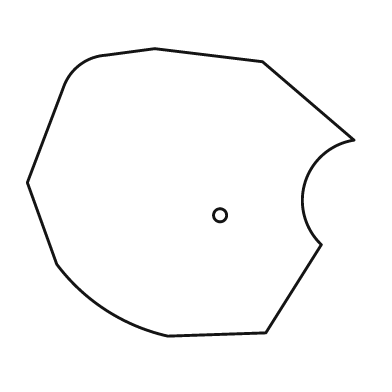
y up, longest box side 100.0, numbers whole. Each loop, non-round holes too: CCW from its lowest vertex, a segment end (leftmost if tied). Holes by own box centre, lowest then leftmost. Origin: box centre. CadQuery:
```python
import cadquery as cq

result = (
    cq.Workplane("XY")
    .moveTo(-7.0, -44.0)
    .lineTo(23.0, -43.0)
    .lineTo(40.0, -16.0)
    .threePointArc((35.0, 3.0), (50.0, 16.0))
    .lineTo(22.0, 40.0)
    .lineTo(-11.0, 44.0)
    .lineTo(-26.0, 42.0)
    .threePointArc((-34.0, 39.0), (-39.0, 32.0))
    .lineTo(-50.0, 3.0)
    .lineTo(-41.0, -22.0)
    .threePointArc((-26.0, -36.0), (-7.0, -44.0))
    .close()
    .moveTo(9.0, -7.0)
    .circle(2.0)
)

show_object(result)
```